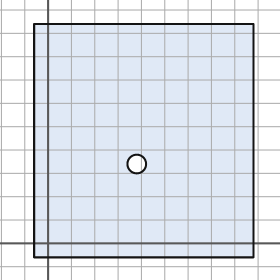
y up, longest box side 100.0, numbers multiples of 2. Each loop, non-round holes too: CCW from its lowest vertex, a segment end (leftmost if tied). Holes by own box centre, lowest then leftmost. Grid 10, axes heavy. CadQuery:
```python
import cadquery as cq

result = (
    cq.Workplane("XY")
    .moveTo(-6.0, -6.0)
    .lineTo(88.0, -6.0)
    .lineTo(88.0, 94.0)
    .lineTo(-6.0, 94.0)
    .close()
    .moveTo(38.0, 34.0)
    .circle(4.0)
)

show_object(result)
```